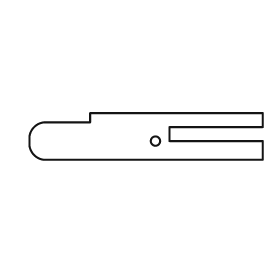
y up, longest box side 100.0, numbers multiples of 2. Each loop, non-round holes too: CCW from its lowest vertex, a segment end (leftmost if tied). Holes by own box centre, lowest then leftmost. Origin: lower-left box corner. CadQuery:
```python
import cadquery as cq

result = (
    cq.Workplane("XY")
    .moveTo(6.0, 0.0)
    .lineTo(100.0, 0.0)
    .lineTo(100.0, 8.0)
    .lineTo(60.0, 8.0)
    .lineTo(60.0, 14.0)
    .lineTo(100.0, 14.0)
    .lineTo(100.0, 20.0)
    .lineTo(26.0, 20.0)
    .lineTo(26.0, 16.0)
    .lineTo(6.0, 16.0)
    .threePointArc((2.0, 14.0), (0.0, 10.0))
    .lineTo(0.0, 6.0)
    .threePointArc((2.0, 2.0), (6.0, 0.0))
    .close()
    .moveTo(54.0, 8.0)
    .circle(2.0)
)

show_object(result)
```